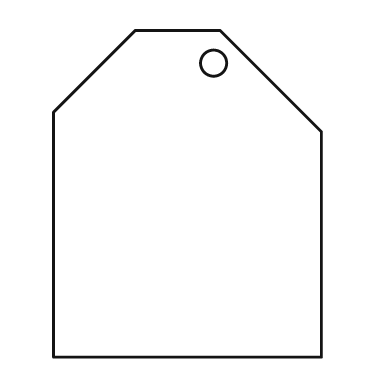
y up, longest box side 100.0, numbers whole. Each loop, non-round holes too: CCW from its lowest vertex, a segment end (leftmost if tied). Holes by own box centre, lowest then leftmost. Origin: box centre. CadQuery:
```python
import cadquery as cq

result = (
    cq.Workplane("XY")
    .moveTo(-41.0, -50.0)
    .lineTo(41.0, -50.0)
    .lineTo(41.0, 19.0)
    .lineTo(10.0, 50.0)
    .lineTo(-16.0, 50.0)
    .lineTo(-41.0, 25.0)
    .close()
    .moveTo(8.0, 40.0)
    .circle(4.0)
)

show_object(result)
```